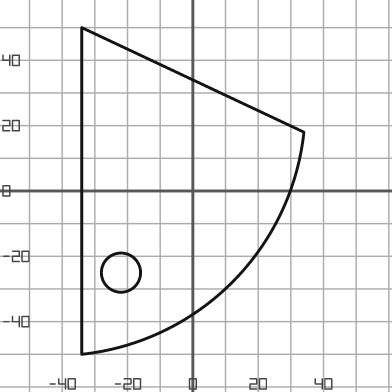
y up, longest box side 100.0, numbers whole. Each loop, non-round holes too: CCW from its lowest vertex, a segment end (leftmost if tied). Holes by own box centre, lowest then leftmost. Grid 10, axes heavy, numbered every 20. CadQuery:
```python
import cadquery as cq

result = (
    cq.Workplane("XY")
    .moveTo(-34.0, -50.0)
    .threePointArc((12.0, -28.0), (34.0, 18.0))
    .lineTo(-34.0, 50.0)
    .close()
    .moveTo(-22.0, -25.0)
    .circle(6.0)
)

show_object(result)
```